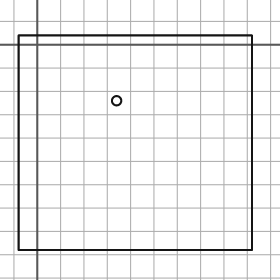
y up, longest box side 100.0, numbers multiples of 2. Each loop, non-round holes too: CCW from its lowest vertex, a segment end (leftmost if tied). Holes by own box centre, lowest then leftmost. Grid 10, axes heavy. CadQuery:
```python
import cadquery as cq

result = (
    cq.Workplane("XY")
    .moveTo(-8.0, -88.0)
    .lineTo(92.0, -88.0)
    .lineTo(92.0, 4.0)
    .lineTo(-8.0, 4.0)
    .close()
    .moveTo(34.0, -24.0)
    .circle(2.0)
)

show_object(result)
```